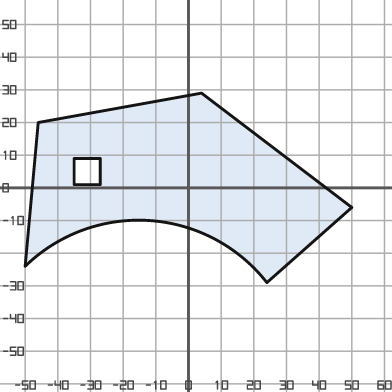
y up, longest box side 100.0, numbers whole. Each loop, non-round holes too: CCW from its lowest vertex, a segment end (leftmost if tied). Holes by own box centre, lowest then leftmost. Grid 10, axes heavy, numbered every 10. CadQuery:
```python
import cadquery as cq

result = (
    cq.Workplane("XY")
    .moveTo(24.0, -29.0)
    .lineTo(50.0, -6.0)
    .lineTo(4.0, 29.0)
    .lineTo(-46.0, 20.0)
    .lineTo(-50.0, -24.0)
    .threePointArc((-12.0, -10.0), (24.0, -29.0))
    .close()
    .moveTo(-35.0, 1.0)
    .lineTo(-27.0, 1.0)
    .lineTo(-27.0, 9.0)
    .lineTo(-35.0, 9.0)
    .close()
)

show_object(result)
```